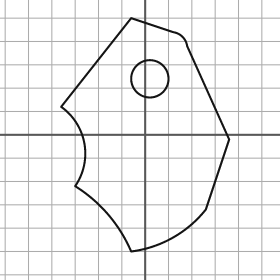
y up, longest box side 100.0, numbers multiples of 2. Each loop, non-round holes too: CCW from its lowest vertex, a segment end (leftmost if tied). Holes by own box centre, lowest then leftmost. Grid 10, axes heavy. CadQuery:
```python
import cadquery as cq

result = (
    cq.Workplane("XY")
    .moveTo(-6.0, -50.0)
    .threePointArc((12.0, -44.0), (26.0, -32.0))
    .lineTo(36.0, -2.0)
    .lineTo(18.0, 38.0)
    .threePointArc((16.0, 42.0), (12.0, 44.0))
    .lineTo(-6.0, 50.0)
    .lineTo(-36.0, 12.0)
    .threePointArc((-26.0, -4.0), (-30.0, -22.0))
    .threePointArc((-16.0, -34.0), (-6.0, -50.0))
    .close()
    .moveTo(2.0, 24.0)
    .circle(8.0)
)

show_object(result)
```